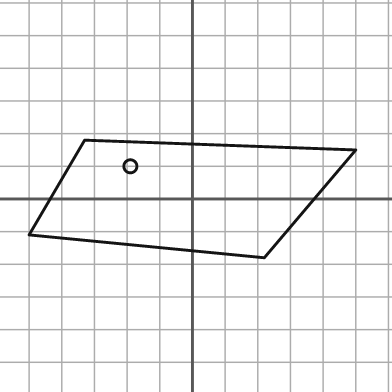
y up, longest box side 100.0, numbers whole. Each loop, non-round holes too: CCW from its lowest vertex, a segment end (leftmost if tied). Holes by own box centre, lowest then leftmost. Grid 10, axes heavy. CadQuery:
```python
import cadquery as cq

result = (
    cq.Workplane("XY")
    .moveTo(22.0, -18.0)
    .lineTo(50.0, 15.0)
    .lineTo(-33.0, 18.0)
    .lineTo(-50.0, -11.0)
    .close()
    .moveTo(-19.0, 10.0)
    .circle(2.0)
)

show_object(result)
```